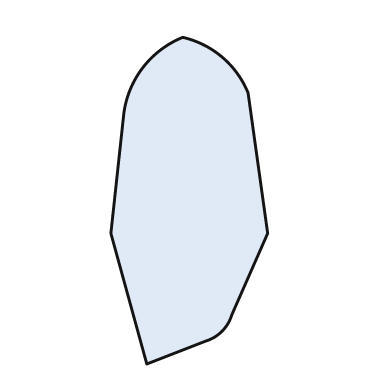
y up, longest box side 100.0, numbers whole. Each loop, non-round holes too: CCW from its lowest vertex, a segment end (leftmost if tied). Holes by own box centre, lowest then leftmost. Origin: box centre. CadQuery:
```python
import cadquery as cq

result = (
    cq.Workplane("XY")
    .moveTo(-13.0, -50.0)
    .lineTo(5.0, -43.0)
    .threePointArc((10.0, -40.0), (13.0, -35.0))
    .lineTo(24.0, -10.0)
    .lineTo(18.0, 33.0)
    .threePointArc((10.0, 44.0), (-2.0, 50.0))
    .threePointArc((-14.0, 41.0), (-20.0, 27.0))
    .lineTo(-24.0, -10.0)
    .close()
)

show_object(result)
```